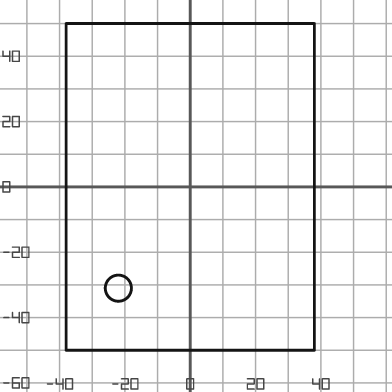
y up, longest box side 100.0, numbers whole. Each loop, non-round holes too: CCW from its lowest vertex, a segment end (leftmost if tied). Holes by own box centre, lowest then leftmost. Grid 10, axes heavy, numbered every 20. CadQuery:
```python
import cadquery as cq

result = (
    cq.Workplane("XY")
    .moveTo(-38.0, -50.0)
    .lineTo(38.0, -50.0)
    .lineTo(38.0, 50.0)
    .lineTo(-38.0, 50.0)
    .close()
    .moveTo(-22.0, -31.0)
    .circle(4.0)
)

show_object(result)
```